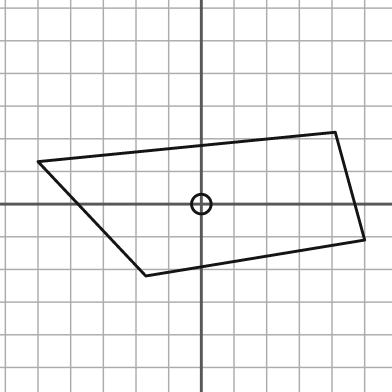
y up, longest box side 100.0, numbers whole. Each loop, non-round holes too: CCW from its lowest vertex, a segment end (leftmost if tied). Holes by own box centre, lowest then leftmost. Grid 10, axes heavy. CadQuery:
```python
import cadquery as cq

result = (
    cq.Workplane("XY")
    .moveTo(-17.0, -22.0)
    .lineTo(50.0, -11.0)
    .lineTo(41.0, 22.0)
    .lineTo(-50.0, 13.0)
    .close()
    .moveTo(0.0, 0.0)
    .circle(3.0)
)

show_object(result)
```